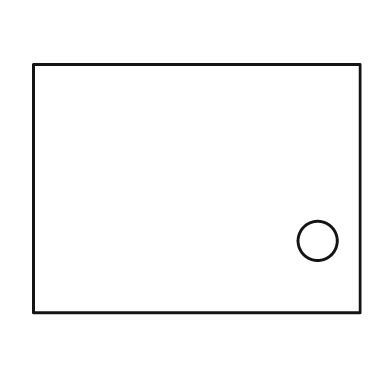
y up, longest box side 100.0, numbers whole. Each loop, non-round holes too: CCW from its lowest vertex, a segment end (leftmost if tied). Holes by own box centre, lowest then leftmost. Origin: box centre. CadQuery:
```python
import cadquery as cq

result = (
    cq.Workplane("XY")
    .moveTo(-50.0, -38.0)
    .lineTo(50.0, -38.0)
    .lineTo(50.0, 38.0)
    .lineTo(-50.0, 38.0)
    .close()
    .moveTo(37.0, -16.0)
    .circle(6.0)
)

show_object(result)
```